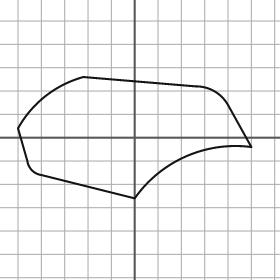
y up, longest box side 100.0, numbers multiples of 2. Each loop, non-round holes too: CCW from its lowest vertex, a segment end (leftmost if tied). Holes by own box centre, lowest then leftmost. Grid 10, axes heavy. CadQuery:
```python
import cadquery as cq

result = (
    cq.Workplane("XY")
    .moveTo(0.0, -26.0)
    .threePointArc((22.0, -8.0), (50.0, -4.0))
    .lineTo(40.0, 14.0)
    .threePointArc((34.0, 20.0), (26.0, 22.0))
    .lineTo(-22.0, 26.0)
    .threePointArc((-38.0, 18.0), (-50.0, 4.0))
    .lineTo(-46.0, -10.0)
    .threePointArc((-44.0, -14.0), (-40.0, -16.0))
    .close()
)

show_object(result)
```